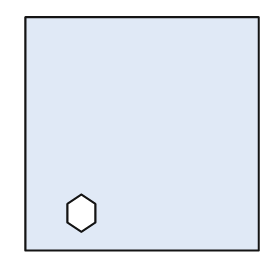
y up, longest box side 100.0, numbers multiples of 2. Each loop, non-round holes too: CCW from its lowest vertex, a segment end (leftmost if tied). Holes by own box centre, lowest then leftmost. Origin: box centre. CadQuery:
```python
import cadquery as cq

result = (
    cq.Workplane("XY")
    .moveTo(-50.0, -50.0)
    .lineTo(50.0, -50.0)
    .lineTo(50.0, 50.0)
    .lineTo(-50.0, 50.0)
    .close()
    .moveTo(-26.0, -42.0)
    .lineTo(-20.0, -38.0)
    .lineTo(-20.0, -30.0)
    .lineTo(-26.0, -26.0)
    .lineTo(-32.0, -30.0)
    .lineTo(-32.0, -38.0)
    .close()
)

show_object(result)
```